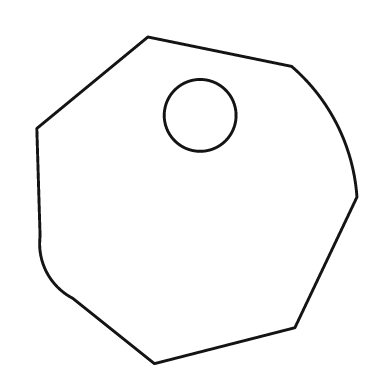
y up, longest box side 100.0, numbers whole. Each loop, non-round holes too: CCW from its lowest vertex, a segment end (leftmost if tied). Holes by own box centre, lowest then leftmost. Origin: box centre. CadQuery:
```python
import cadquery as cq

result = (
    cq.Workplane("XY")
    .moveTo(-13.0, -50.0)
    .lineTo(30.0, -39.0)
    .lineTo(49.0, 1.0)
    .threePointArc((43.0, 23.0), (29.0, 41.0))
    .lineTo(-15.0, 50.0)
    .lineTo(-49.0, 22.0)
    .lineTo(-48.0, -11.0)
    .threePointArc((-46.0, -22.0), (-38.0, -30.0))
    .close()
    .moveTo(1.0, 26.0)
    .circle(11.0)
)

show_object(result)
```